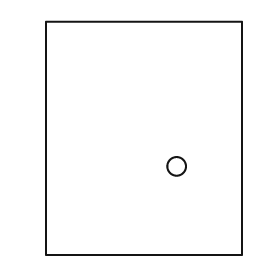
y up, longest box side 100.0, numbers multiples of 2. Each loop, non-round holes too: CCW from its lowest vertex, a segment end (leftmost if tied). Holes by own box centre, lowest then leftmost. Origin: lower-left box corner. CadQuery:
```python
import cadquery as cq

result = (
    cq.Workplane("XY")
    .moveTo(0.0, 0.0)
    .lineTo(84.0, 0.0)
    .lineTo(84.0, 100.0)
    .lineTo(0.0, 100.0)
    .close()
    .moveTo(56.0, 38.0)
    .circle(4.0)
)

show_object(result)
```